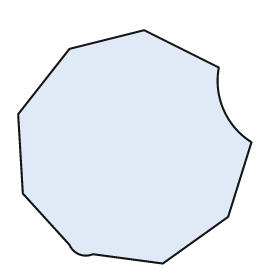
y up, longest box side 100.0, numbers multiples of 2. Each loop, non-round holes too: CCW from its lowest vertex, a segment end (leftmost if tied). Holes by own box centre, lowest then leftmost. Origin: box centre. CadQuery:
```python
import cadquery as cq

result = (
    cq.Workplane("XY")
    .moveTo(12.0, -50.0)
    .lineTo(40.0, -30.0)
    .lineTo(50.0, 2.0)
    .threePointArc((38.0, 16.0), (36.0, 34.0))
    .lineTo(4.0, 50.0)
    .lineTo(-28.0, 42.0)
    .lineTo(-50.0, 14.0)
    .lineTo(-48.0, -20.0)
    .lineTo(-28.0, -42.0)
    .threePointArc((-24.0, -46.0), (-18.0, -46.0))
    .close()
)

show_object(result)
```